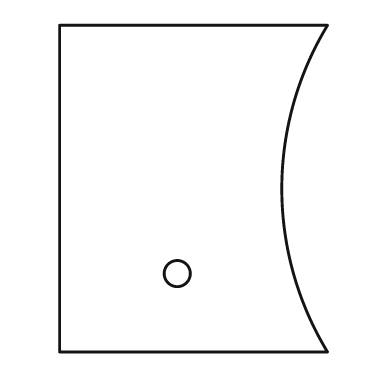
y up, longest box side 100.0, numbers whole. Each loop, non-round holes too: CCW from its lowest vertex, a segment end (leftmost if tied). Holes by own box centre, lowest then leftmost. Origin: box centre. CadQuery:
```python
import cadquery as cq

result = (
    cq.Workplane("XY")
    .moveTo(-41.0, -50.0)
    .lineTo(41.0, -50.0)
    .threePointArc((27.0, 0.0), (41.0, 50.0))
    .lineTo(-41.0, 50.0)
    .close()
    .moveTo(-5.0, -26.0)
    .circle(4.0)
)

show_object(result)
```